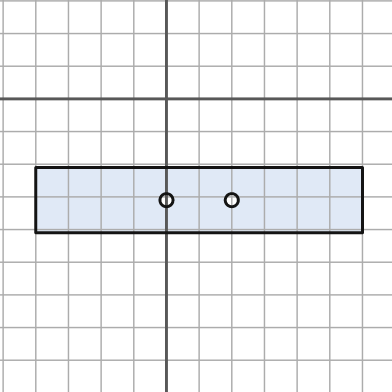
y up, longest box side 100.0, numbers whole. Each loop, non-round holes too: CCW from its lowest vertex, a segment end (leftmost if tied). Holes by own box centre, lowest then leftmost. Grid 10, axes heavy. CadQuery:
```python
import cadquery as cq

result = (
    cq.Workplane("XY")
    .moveTo(-40.0, -41.0)
    .lineTo(60.0, -41.0)
    .lineTo(60.0, -21.0)
    .lineTo(-40.0, -21.0)
    .close()
    .moveTo(0.0, -31.0)
    .circle(2.0)
    .moveTo(20.0, -31.0)
    .circle(2.0)
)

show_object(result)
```